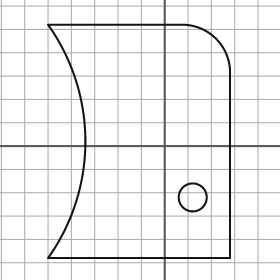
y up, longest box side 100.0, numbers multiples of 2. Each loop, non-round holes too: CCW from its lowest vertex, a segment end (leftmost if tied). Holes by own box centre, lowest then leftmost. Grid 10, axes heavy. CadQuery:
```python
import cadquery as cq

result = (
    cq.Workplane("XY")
    .moveTo(-50.0, -48.0)
    .lineTo(28.0, -48.0)
    .lineTo(28.0, 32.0)
    .threePointArc((22.0, 46.0), (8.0, 52.0))
    .lineTo(-50.0, 52.0)
    .threePointArc((-34.0, 2.0), (-50.0, -48.0))
    .close()
    .moveTo(12.0, -22.0)
    .circle(6.0)
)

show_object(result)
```